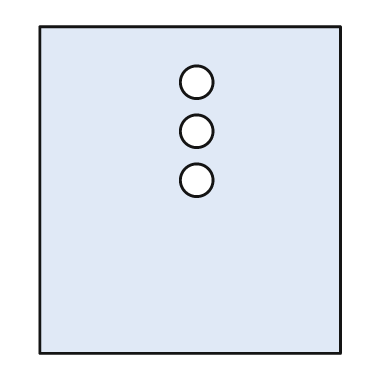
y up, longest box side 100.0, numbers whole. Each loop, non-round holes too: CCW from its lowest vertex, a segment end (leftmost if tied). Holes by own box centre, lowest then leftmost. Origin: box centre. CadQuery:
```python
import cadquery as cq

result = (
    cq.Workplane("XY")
    .moveTo(-46.0, -50.0)
    .lineTo(46.0, -50.0)
    .lineTo(46.0, 50.0)
    .lineTo(-46.0, 50.0)
    .close()
    .moveTo(2.0, 3.0)
    .circle(5.0)
    .moveTo(2.0, 18.0)
    .circle(5.0)
    .moveTo(2.0, 33.0)
    .circle(5.0)
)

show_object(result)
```